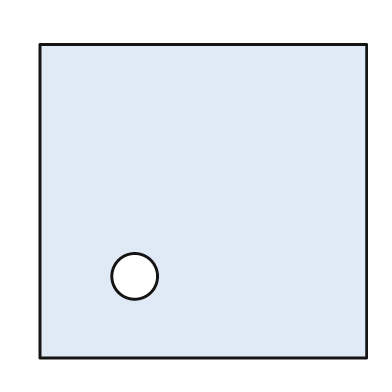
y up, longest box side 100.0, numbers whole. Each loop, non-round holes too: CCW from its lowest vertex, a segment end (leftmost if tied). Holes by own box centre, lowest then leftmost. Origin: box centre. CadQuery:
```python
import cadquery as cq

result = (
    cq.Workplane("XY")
    .moveTo(-50.0, -48.0)
    .lineTo(50.0, -48.0)
    .lineTo(50.0, 48.0)
    .lineTo(-50.0, 48.0)
    .close()
    .moveTo(-21.0, -23.0)
    .circle(7.0)
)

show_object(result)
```